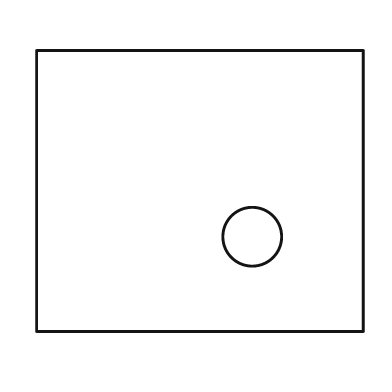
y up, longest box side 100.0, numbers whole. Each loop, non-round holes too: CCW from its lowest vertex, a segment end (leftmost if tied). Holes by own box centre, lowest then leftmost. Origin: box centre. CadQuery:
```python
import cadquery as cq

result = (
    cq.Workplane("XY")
    .moveTo(-50.0, -43.0)
    .lineTo(50.0, -43.0)
    .lineTo(50.0, 43.0)
    .lineTo(-50.0, 43.0)
    .close()
    .moveTo(16.0, -14.0)
    .circle(9.0)
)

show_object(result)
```